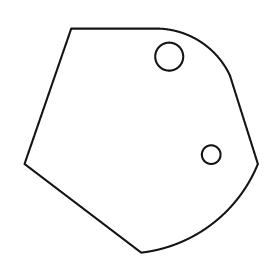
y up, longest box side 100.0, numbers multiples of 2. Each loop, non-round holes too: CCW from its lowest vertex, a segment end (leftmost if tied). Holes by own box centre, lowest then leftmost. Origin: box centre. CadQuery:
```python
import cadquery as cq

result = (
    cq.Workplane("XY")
    .moveTo(0.0, -48.0)
    .threePointArc((30.0, -36.0), (50.0, -10.0))
    .lineTo(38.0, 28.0)
    .threePointArc((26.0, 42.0), (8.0, 48.0))
    .lineTo(-30.0, 48.0)
    .lineTo(-50.0, -10.0)
    .close()
    .moveTo(30.0, -6.0)
    .circle(4.0)
    .moveTo(12.0, 36.0)
    .circle(6.0)
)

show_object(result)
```